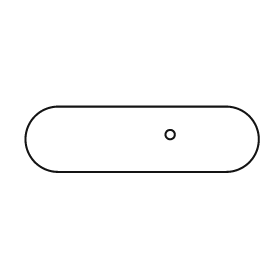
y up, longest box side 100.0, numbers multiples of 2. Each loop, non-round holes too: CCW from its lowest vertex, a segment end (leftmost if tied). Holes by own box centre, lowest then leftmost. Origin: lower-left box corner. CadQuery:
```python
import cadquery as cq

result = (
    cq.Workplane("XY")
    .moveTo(14.0, 0.0)
    .lineTo(86.0, 0.0)
    .threePointArc((100.0, 14.0), (86.0, 28.0))
    .lineTo(14.0, 28.0)
    .threePointArc((0.0, 14.0), (14.0, 0.0))
    .close()
    .moveTo(62.0, 16.0)
    .circle(2.0)
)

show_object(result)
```